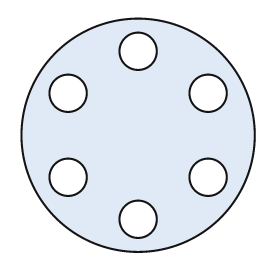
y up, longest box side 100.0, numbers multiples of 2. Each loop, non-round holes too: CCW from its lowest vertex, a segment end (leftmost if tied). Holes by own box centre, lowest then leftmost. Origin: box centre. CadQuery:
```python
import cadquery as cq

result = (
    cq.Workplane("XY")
    .moveTo(0.0, 0.0)
    .circle(50.0)
    .moveTo(0.0, -36.0)
    .circle(8.0)
    .moveTo(-30.0, -18.0)
    .circle(8.0)
    .moveTo(30.0, -18.0)
    .circle(8.0)
    .moveTo(-30.0, 18.0)
    .circle(8.0)
    .moveTo(30.0, 18.0)
    .circle(8.0)
    .moveTo(0.0, 36.0)
    .circle(8.0)
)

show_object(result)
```